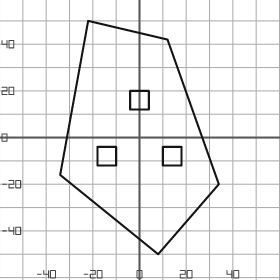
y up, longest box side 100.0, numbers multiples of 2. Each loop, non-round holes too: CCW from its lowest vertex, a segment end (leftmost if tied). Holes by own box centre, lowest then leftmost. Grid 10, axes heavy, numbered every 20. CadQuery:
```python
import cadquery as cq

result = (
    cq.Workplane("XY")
    .moveTo(8.0, -50.0)
    .lineTo(34.0, -20.0)
    .lineTo(12.0, 42.0)
    .lineTo(-22.0, 50.0)
    .lineTo(-34.0, -16.0)
    .close()
    .moveTo(-18.0, -12.0)
    .lineTo(-10.0, -12.0)
    .lineTo(-10.0, -4.0)
    .lineTo(-18.0, -4.0)
    .close()
    .moveTo(10.0, -12.0)
    .lineTo(18.0, -12.0)
    .lineTo(18.0, -4.0)
    .lineTo(10.0, -4.0)
    .close()
    .moveTo(-4.0, 12.0)
    .lineTo(4.0, 12.0)
    .lineTo(4.0, 20.0)
    .lineTo(-4.0, 20.0)
    .close()
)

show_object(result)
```